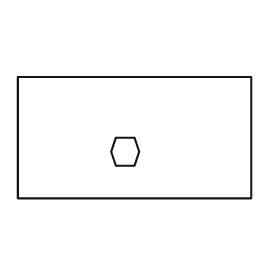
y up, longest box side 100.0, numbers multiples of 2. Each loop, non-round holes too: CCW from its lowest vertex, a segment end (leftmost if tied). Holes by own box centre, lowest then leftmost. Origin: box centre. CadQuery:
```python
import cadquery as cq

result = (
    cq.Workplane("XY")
    .moveTo(-50.0, -26.0)
    .lineTo(50.0, -26.0)
    .lineTo(50.0, 26.0)
    .lineTo(-50.0, 26.0)
    .close()
    .moveTo(-8.0, -12.0)
    .lineTo(0.0, -12.0)
    .lineTo(2.0, -6.0)
    .lineTo(0.0, 0.0)
    .lineTo(-8.0, 0.0)
    .lineTo(-10.0, -6.0)
    .close()
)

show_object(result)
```